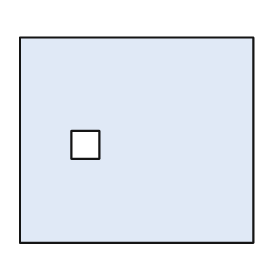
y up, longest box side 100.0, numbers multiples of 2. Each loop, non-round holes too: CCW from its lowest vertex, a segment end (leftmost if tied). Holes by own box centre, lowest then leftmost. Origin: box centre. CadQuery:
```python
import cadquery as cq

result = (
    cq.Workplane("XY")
    .moveTo(-50.0, -44.0)
    .lineTo(50.0, -44.0)
    .lineTo(50.0, 44.0)
    .lineTo(-50.0, 44.0)
    .close()
    .moveTo(-28.0, -8.0)
    .lineTo(-16.0, -8.0)
    .lineTo(-16.0, 4.0)
    .lineTo(-28.0, 4.0)
    .close()
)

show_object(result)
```